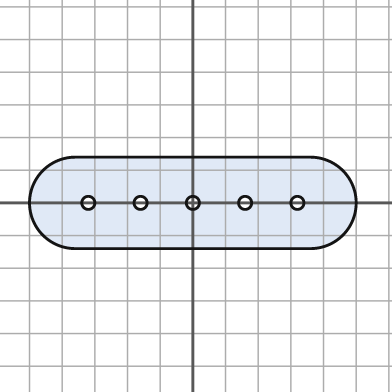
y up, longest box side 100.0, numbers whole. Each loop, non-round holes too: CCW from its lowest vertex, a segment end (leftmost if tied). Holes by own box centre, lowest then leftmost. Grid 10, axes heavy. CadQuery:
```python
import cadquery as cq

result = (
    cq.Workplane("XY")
    .moveTo(-36.0, -14.0)
    .lineTo(36.0, -14.0)
    .threePointArc((50.0, 0.0), (36.0, 14.0))
    .lineTo(-36.0, 14.0)
    .threePointArc((-50.0, 0.0), (-36.0, -14.0))
    .close()
    .moveTo(-32.0, 0.0)
    .circle(2.0)
    .moveTo(-16.0, 0.0)
    .circle(2.0)
    .moveTo(0.0, 0.0)
    .circle(2.0)
    .moveTo(16.0, 0.0)
    .circle(2.0)
    .moveTo(32.0, 0.0)
    .circle(2.0)
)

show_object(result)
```